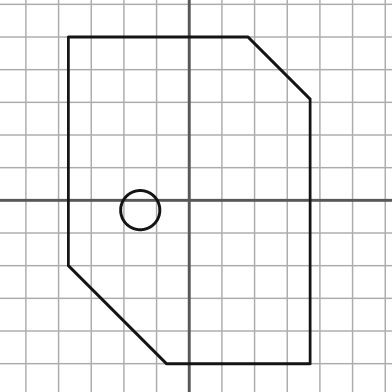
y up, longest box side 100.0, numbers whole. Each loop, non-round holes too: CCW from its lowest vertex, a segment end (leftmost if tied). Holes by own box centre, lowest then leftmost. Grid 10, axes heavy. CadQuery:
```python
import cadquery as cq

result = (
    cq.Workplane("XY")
    .moveTo(-7.0, -50.0)
    .lineTo(37.0, -50.0)
    .lineTo(37.0, 31.0)
    .lineTo(18.0, 50.0)
    .lineTo(-37.0, 50.0)
    .lineTo(-37.0, -20.0)
    .close()
    .moveTo(-15.0, -3.0)
    .circle(6.0)
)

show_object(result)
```